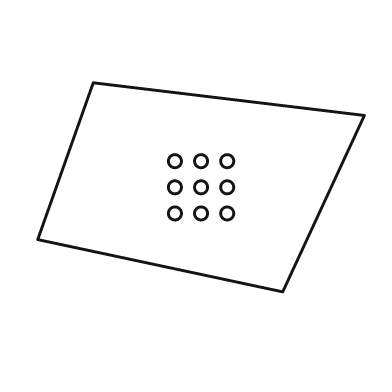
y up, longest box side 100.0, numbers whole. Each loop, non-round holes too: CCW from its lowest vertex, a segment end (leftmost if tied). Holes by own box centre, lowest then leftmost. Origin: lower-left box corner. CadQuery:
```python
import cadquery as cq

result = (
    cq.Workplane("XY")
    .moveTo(75.0, 0.0)
    .lineTo(100.0, 54.0)
    .lineTo(17.0, 64.0)
    .lineTo(0.0, 16.0)
    .close()
    .moveTo(42.0, 24.0)
    .circle(2.0)
    .moveTo(50.0, 24.0)
    .circle(2.0)
    .moveTo(58.0, 24.0)
    .circle(2.0)
    .moveTo(42.0, 32.0)
    .circle(2.0)
    .moveTo(50.0, 32.0)
    .circle(2.0)
    .moveTo(58.0, 32.0)
    .circle(2.0)
    .moveTo(42.0, 40.0)
    .circle(2.0)
    .moveTo(50.0, 40.0)
    .circle(2.0)
    .moveTo(58.0, 40.0)
    .circle(2.0)
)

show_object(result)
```